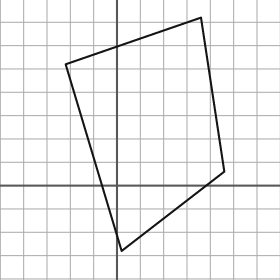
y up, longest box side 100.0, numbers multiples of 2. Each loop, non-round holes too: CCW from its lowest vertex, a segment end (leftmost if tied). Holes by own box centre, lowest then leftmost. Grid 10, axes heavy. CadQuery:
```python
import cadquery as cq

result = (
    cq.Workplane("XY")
    .moveTo(2.0, -28.0)
    .lineTo(46.0, 6.0)
    .lineTo(36.0, 72.0)
    .lineTo(-22.0, 52.0)
    .close()
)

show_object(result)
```